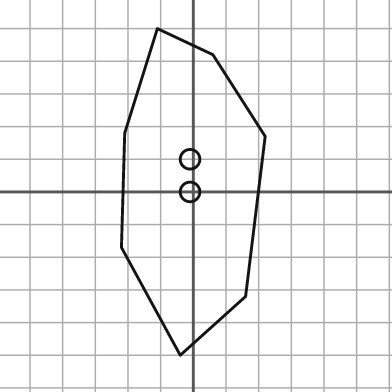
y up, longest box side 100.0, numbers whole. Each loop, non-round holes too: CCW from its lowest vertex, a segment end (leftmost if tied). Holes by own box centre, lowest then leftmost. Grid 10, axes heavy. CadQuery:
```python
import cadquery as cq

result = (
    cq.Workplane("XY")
    .moveTo(-4.0, -50.0)
    .lineTo(16.0, -32.0)
    .lineTo(22.0, 17.0)
    .lineTo(6.0, 42.0)
    .lineTo(-11.0, 50.0)
    .lineTo(-21.0, 18.0)
    .lineTo(-22.0, -17.0)
    .close()
    .moveTo(-1.0, 0.0)
    .circle(3.0)
    .moveTo(-1.0, 10.0)
    .circle(3.0)
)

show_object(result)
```